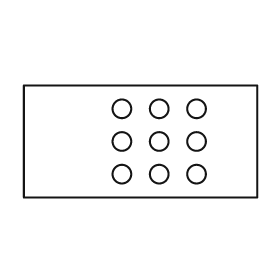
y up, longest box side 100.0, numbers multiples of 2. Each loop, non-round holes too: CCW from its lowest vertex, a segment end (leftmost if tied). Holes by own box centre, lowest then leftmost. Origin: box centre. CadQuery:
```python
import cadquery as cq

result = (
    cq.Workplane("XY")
    .moveTo(-50.0, -24.0)
    .lineTo(50.0, -24.0)
    .lineTo(50.0, 24.0)
    .lineTo(-50.0, 24.0)
    .close()
    .moveTo(-8.0, -14.0)
    .circle(4.0)
    .moveTo(8.0, -14.0)
    .circle(4.0)
    .moveTo(24.0, -14.0)
    .circle(4.0)
    .moveTo(-8.0, 0.0)
    .circle(4.0)
    .moveTo(8.0, 0.0)
    .circle(4.0)
    .moveTo(24.0, 0.0)
    .circle(4.0)
    .moveTo(-8.0, 14.0)
    .circle(4.0)
    .moveTo(8.0, 14.0)
    .circle(4.0)
    .moveTo(24.0, 14.0)
    .circle(4.0)
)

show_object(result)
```